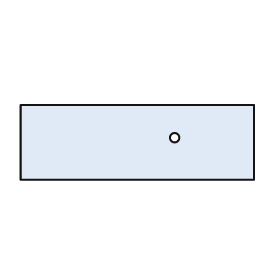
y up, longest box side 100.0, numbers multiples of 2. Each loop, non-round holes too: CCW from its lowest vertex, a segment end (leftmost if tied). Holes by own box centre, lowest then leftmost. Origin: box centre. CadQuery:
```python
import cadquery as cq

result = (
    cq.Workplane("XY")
    .moveTo(-50.0, -16.0)
    .lineTo(50.0, -16.0)
    .lineTo(50.0, 16.0)
    .lineTo(-50.0, 16.0)
    .close()
    .moveTo(16.0, 2.0)
    .circle(2.0)
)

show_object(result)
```